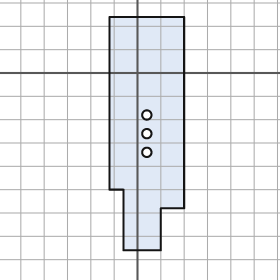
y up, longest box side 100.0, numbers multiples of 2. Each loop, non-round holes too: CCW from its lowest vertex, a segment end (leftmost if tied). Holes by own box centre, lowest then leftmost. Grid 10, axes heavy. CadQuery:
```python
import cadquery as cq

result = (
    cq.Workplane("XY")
    .moveTo(-6.0, -76.0)
    .lineTo(10.0, -76.0)
    .lineTo(10.0, -58.0)
    .lineTo(20.0, -58.0)
    .lineTo(20.0, 24.0)
    .lineTo(-12.0, 24.0)
    .lineTo(-12.0, -50.0)
    .lineTo(-6.0, -50.0)
    .close()
    .moveTo(4.0, -34.0)
    .circle(2.0)
    .moveTo(4.0, -26.0)
    .circle(2.0)
    .moveTo(4.0, -18.0)
    .circle(2.0)
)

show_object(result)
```